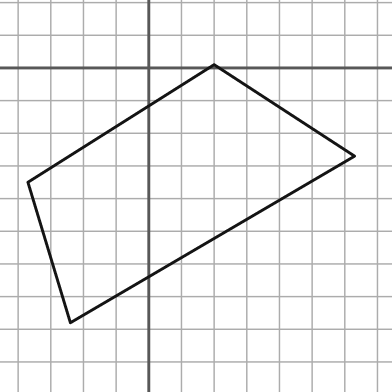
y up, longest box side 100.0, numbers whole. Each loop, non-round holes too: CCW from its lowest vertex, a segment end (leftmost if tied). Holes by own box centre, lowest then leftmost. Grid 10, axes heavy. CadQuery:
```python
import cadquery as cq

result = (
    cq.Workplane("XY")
    .moveTo(-24.0, -78.0)
    .lineTo(63.0, -27.0)
    .lineTo(20.0, 1.0)
    .lineTo(-37.0, -35.0)
    .close()
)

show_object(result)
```